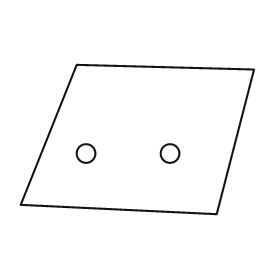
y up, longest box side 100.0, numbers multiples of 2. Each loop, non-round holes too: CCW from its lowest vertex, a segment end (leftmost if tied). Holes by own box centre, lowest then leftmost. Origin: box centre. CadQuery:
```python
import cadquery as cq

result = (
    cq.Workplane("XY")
    .moveTo(34.0, -32.0)
    .lineTo(50.0, 30.0)
    .lineTo(-26.0, 32.0)
    .lineTo(-50.0, -28.0)
    .close()
    .moveTo(-22.0, -6.0)
    .circle(4.0)
    .moveTo(14.0, -6.0)
    .circle(4.0)
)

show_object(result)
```